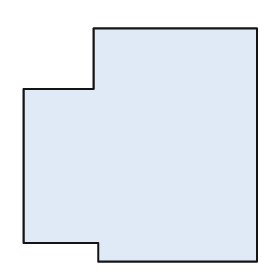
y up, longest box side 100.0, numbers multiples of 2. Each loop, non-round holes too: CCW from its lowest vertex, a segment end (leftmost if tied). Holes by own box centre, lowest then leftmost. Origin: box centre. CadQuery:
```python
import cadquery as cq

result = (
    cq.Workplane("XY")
    .moveTo(-18.0, -50.0)
    .lineTo(50.0, -50.0)
    .lineTo(50.0, 50.0)
    .lineTo(-20.0, 50.0)
    .lineTo(-20.0, 24.0)
    .lineTo(-50.0, 24.0)
    .lineTo(-50.0, -42.0)
    .lineTo(-18.0, -42.0)
    .close()
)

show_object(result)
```